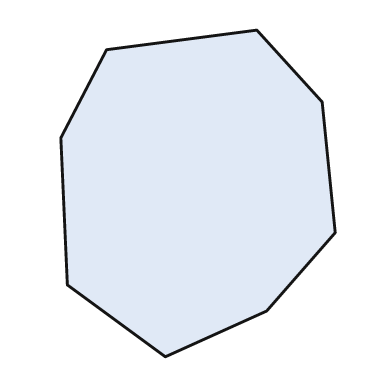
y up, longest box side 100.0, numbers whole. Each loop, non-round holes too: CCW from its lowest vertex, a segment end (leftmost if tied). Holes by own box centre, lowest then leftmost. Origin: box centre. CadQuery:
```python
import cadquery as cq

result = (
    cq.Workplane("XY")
    .moveTo(-10.0, -50.0)
    .lineTo(21.0, -36.0)
    .lineTo(42.0, -12.0)
    .lineTo(38.0, 28.0)
    .lineTo(18.0, 50.0)
    .lineTo(-28.0, 44.0)
    .lineTo(-42.0, 17.0)
    .lineTo(-40.0, -28.0)
    .close()
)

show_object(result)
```